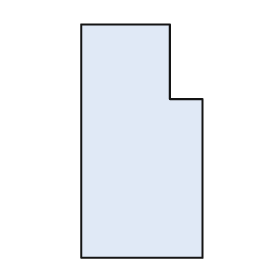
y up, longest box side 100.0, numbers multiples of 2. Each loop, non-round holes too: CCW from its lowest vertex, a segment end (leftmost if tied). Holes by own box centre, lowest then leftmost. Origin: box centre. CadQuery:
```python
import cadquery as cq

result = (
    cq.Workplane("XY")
    .moveTo(-26.0, -50.0)
    .lineTo(26.0, -50.0)
    .lineTo(26.0, 18.0)
    .lineTo(12.0, 18.0)
    .lineTo(12.0, 50.0)
    .lineTo(-26.0, 50.0)
    .close()
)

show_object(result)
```